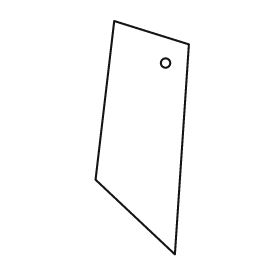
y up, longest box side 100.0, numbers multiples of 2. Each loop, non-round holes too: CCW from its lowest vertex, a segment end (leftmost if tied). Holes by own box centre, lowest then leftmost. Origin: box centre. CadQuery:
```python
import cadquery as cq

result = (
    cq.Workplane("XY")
    .moveTo(14.0, -50.0)
    .lineTo(20.0, 40.0)
    .lineTo(-12.0, 50.0)
    .lineTo(-20.0, -18.0)
    .close()
    .moveTo(10.0, 32.0)
    .circle(2.0)
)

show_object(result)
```